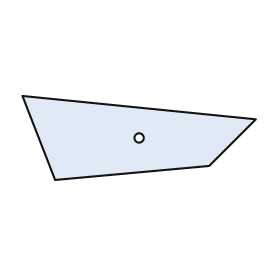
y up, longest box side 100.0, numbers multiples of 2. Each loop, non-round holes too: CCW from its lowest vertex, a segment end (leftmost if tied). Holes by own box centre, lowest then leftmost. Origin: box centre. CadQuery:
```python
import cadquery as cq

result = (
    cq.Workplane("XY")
    .moveTo(-36.0, -18.0)
    .lineTo(30.0, -12.0)
    .lineTo(50.0, 8.0)
    .lineTo(-50.0, 18.0)
    .close()
    .moveTo(0.0, 0.0)
    .circle(2.0)
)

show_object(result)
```